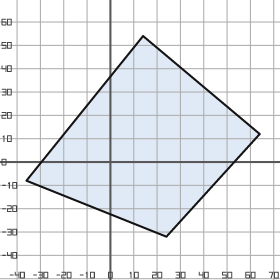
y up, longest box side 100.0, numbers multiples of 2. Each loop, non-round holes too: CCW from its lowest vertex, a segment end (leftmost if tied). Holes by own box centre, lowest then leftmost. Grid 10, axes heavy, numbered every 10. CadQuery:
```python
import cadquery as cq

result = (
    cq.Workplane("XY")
    .moveTo(24.0, -32.0)
    .lineTo(64.0, 12.0)
    .lineTo(14.0, 54.0)
    .lineTo(-36.0, -8.0)
    .close()
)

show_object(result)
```